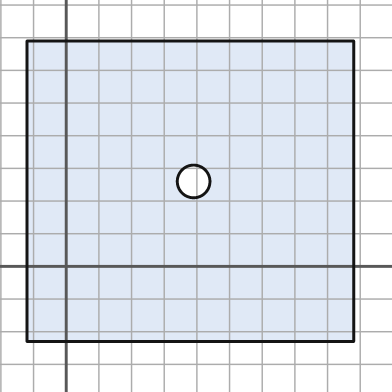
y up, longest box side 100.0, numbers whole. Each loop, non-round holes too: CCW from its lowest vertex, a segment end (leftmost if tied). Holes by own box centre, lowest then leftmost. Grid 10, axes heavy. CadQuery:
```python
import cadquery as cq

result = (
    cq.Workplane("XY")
    .moveTo(-12.0, -23.0)
    .lineTo(88.0, -23.0)
    .lineTo(88.0, 69.0)
    .lineTo(-12.0, 69.0)
    .close()
    .moveTo(39.0, 26.0)
    .circle(5.0)
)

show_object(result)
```